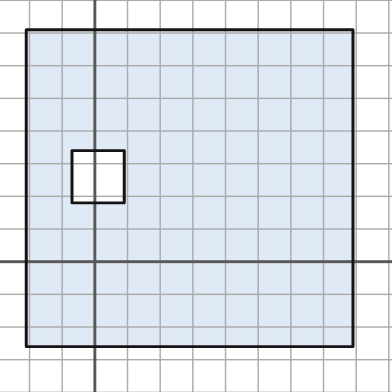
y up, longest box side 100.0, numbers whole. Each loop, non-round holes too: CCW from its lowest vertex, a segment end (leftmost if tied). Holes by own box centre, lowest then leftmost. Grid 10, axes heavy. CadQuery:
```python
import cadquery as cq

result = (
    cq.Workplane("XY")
    .moveTo(-21.0, -26.0)
    .lineTo(79.0, -26.0)
    .lineTo(79.0, 71.0)
    .lineTo(-21.0, 71.0)
    .close()
    .moveTo(-7.0, 18.0)
    .lineTo(9.0, 18.0)
    .lineTo(9.0, 34.0)
    .lineTo(-7.0, 34.0)
    .close()
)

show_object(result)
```